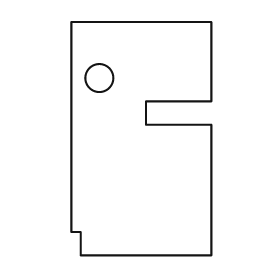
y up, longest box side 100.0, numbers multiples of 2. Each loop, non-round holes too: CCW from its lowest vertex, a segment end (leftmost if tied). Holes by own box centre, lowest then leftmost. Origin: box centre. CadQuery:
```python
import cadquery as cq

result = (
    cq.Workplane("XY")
    .moveTo(-26.0, -50.0)
    .lineTo(30.0, -50.0)
    .lineTo(30.0, 6.0)
    .lineTo(2.0, 6.0)
    .lineTo(2.0, 16.0)
    .lineTo(30.0, 16.0)
    .lineTo(30.0, 50.0)
    .lineTo(-30.0, 50.0)
    .lineTo(-30.0, -40.0)
    .lineTo(-26.0, -40.0)
    .close()
    .moveTo(-18.0, 26.0)
    .circle(6.0)
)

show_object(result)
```